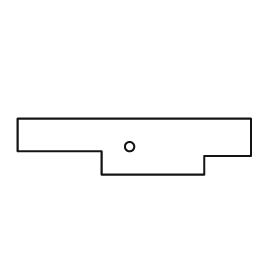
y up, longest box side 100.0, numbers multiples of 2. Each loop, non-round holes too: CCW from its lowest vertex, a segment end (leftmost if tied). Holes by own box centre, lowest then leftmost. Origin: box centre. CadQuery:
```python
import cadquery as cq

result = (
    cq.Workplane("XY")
    .moveTo(-14.0, -12.0)
    .lineTo(30.0, -12.0)
    .lineTo(30.0, -4.0)
    .lineTo(50.0, -4.0)
    .lineTo(50.0, 12.0)
    .lineTo(-50.0, 12.0)
    .lineTo(-50.0, -2.0)
    .lineTo(-14.0, -2.0)
    .close()
    .moveTo(-2.0, 0.0)
    .circle(2.0)
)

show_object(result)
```